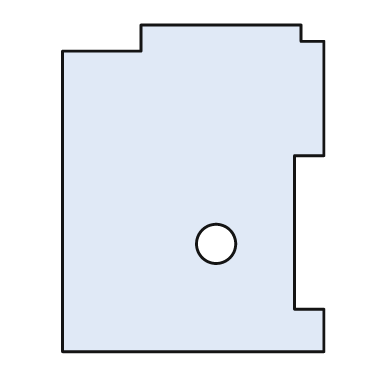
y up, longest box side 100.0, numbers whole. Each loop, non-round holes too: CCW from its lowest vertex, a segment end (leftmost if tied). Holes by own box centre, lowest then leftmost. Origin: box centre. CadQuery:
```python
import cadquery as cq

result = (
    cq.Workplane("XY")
    .moveTo(-40.0, -50.0)
    .lineTo(40.0, -50.0)
    .lineTo(40.0, -37.0)
    .lineTo(31.0, -37.0)
    .lineTo(31.0, 10.0)
    .lineTo(40.0, 10.0)
    .lineTo(40.0, 45.0)
    .lineTo(33.0, 45.0)
    .lineTo(33.0, 50.0)
    .lineTo(-16.0, 50.0)
    .lineTo(-16.0, 42.0)
    .lineTo(-40.0, 42.0)
    .close()
    .moveTo(7.0, -17.0)
    .circle(6.0)
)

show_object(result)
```